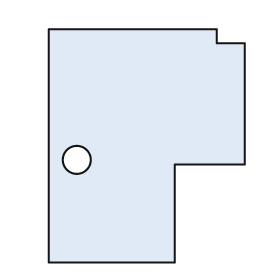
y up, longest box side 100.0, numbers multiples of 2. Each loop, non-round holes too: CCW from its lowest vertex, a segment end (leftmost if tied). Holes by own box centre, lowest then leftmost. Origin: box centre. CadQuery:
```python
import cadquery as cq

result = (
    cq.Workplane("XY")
    .moveTo(-42.0, -50.0)
    .lineTo(12.0, -50.0)
    .lineTo(12.0, -8.0)
    .lineTo(42.0, -8.0)
    .lineTo(42.0, 44.0)
    .lineTo(30.0, 44.0)
    .lineTo(30.0, 50.0)
    .lineTo(-42.0, 50.0)
    .close()
    .moveTo(-30.0, -6.0)
    .circle(6.0)
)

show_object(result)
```